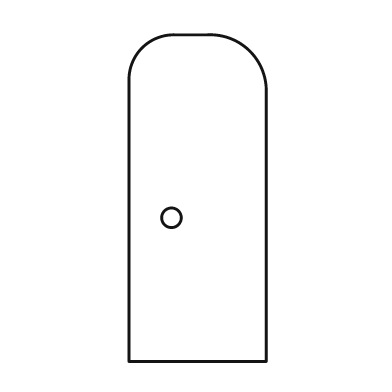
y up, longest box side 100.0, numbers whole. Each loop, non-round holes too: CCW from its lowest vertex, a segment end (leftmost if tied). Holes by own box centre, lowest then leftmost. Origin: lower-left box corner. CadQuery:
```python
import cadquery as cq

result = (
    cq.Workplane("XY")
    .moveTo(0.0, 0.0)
    .lineTo(42.0, 0.0)
    .lineTo(42.0, 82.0)
    .threePointArc((37.0, 95.0), (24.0, 100.0))
    .lineTo(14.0, 100.0)
    .threePointArc((4.0, 96.0), (0.0, 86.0))
    .close()
    .moveTo(13.0, 44.0)
    .circle(3.0)
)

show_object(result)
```